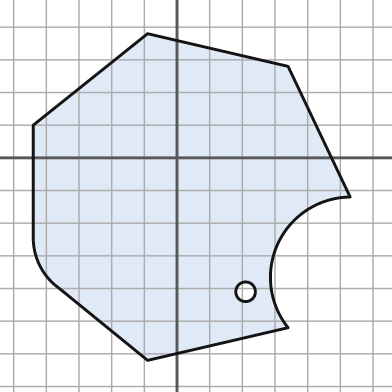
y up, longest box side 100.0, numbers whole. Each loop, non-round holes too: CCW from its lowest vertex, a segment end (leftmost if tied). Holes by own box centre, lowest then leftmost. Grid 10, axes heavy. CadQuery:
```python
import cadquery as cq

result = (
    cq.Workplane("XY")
    .moveTo(-9.0, -62.0)
    .lineTo(34.0, -52.0)
    .threePointArc((31.0, -26.0), (53.0, -12.0))
    .lineTo(34.0, 28.0)
    .lineTo(-9.0, 38.0)
    .lineTo(-44.0, 10.0)
    .lineTo(-44.0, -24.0)
    .threePointArc((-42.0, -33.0), (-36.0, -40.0))
    .close()
    .moveTo(21.0, -41.0)
    .circle(3.0)
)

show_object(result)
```